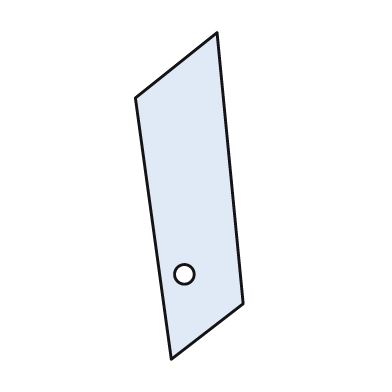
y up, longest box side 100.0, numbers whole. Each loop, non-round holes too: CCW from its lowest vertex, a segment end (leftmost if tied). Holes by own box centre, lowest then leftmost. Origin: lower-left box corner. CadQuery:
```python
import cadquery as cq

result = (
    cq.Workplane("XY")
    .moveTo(11.0, 0.0)
    .lineTo(33.0, 17.0)
    .lineTo(25.0, 100.0)
    .lineTo(0.0, 80.0)
    .close()
    .moveTo(15.0, 26.0)
    .circle(3.0)
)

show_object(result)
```